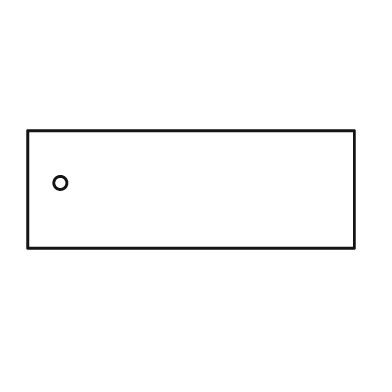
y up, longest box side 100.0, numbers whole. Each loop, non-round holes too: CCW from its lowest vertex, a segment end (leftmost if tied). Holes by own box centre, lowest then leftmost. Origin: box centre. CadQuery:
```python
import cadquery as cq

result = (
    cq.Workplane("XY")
    .moveTo(-50.0, -18.0)
    .lineTo(50.0, -18.0)
    .lineTo(50.0, 18.0)
    .lineTo(-50.0, 18.0)
    .close()
    .moveTo(-40.0, 2.0)
    .circle(2.0)
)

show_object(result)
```